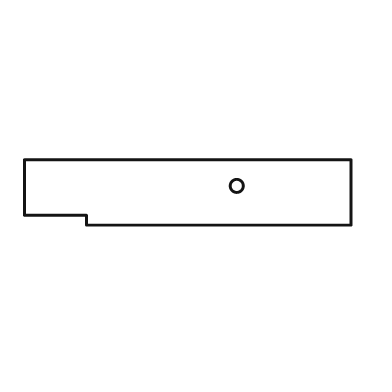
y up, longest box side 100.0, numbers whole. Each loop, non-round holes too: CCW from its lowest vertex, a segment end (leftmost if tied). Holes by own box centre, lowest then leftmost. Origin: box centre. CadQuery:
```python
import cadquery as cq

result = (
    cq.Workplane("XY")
    .moveTo(-31.0, -10.0)
    .lineTo(50.0, -10.0)
    .lineTo(50.0, 10.0)
    .lineTo(-50.0, 10.0)
    .lineTo(-50.0, -7.0)
    .lineTo(-31.0, -7.0)
    .close()
    .moveTo(15.0, 2.0)
    .circle(2.0)
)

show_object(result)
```